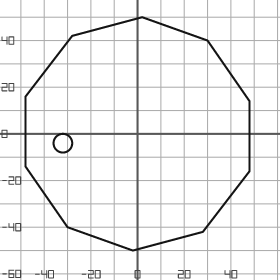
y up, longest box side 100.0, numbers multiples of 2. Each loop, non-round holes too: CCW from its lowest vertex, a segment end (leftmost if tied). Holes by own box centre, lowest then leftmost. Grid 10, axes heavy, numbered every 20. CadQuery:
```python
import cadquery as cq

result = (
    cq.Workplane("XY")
    .moveTo(-2.0, -50.0)
    .lineTo(28.0, -42.0)
    .lineTo(48.0, -16.0)
    .lineTo(48.0, 14.0)
    .lineTo(30.0, 40.0)
    .lineTo(2.0, 50.0)
    .lineTo(-28.0, 42.0)
    .lineTo(-48.0, 16.0)
    .lineTo(-48.0, -14.0)
    .lineTo(-30.0, -40.0)
    .close()
    .moveTo(-32.0, -4.0)
    .circle(4.0)
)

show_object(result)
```